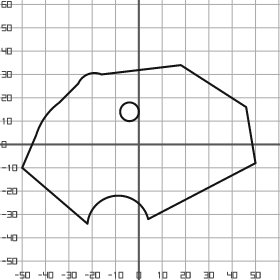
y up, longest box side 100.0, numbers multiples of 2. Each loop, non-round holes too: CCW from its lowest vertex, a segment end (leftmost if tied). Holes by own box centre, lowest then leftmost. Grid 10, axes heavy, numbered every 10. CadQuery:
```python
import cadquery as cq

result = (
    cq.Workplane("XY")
    .moveTo(-22.0, -34.0)
    .threePointArc((-10.0, -22.0), (4.0, -32.0))
    .lineTo(50.0, -8.0)
    .lineTo(46.0, 16.0)
    .lineTo(18.0, 34.0)
    .lineTo(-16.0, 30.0)
    .threePointArc((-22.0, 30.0), (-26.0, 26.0))
    .lineTo(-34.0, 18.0)
    .threePointArc((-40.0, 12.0), (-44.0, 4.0))
    .lineTo(-50.0, -10.0)
    .close()
    .moveTo(-4.0, 14.0)
    .circle(4.0)
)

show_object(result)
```